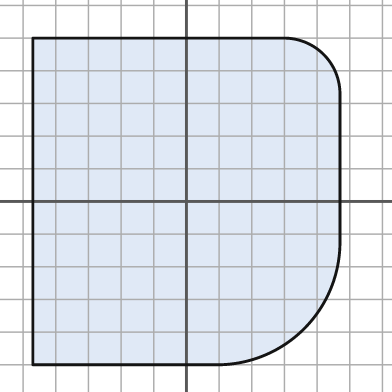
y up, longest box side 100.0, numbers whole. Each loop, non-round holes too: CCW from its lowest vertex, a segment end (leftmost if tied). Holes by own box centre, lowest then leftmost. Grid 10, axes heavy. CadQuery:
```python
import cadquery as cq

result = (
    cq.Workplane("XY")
    .moveTo(-47.0, -50.0)
    .lineTo(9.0, -50.0)
    .threePointArc((36.0, -39.0), (47.0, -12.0))
    .lineTo(47.0, 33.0)
    .threePointArc((42.0, 45.0), (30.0, 50.0))
    .lineTo(-47.0, 50.0)
    .close()
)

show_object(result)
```